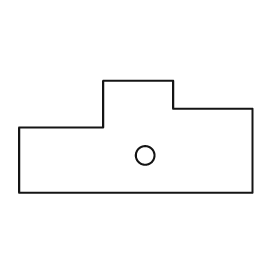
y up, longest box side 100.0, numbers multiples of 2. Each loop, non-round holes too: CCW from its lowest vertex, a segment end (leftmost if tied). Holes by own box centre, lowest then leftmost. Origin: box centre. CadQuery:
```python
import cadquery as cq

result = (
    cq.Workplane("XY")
    .moveTo(-50.0, -24.0)
    .lineTo(50.0, -24.0)
    .lineTo(50.0, 12.0)
    .lineTo(16.0, 12.0)
    .lineTo(16.0, 24.0)
    .lineTo(-14.0, 24.0)
    .lineTo(-14.0, 4.0)
    .lineTo(-50.0, 4.0)
    .close()
    .moveTo(4.0, -8.0)
    .circle(4.0)
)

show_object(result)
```